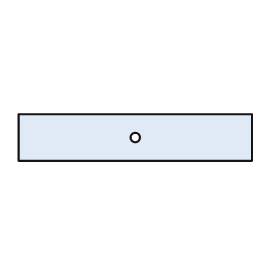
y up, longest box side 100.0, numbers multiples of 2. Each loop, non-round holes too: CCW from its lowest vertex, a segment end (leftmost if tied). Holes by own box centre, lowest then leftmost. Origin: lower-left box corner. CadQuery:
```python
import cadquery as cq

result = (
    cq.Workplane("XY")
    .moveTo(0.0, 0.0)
    .lineTo(100.0, 0.0)
    .lineTo(100.0, 20.0)
    .lineTo(0.0, 20.0)
    .close()
    .moveTo(50.0, 10.0)
    .circle(2.0)
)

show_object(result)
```